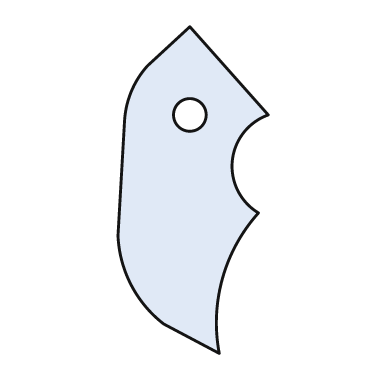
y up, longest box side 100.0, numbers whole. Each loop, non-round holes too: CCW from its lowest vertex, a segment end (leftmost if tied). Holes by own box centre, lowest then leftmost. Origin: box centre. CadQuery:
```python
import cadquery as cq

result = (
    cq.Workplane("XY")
    .moveTo(8.0, -50.0)
    .threePointArc((9.0, -27.0), (20.0, -7.0))
    .threePointArc((12.0, 9.0), (23.0, 23.0))
    .lineTo(-1.0, 50.0)
    .lineTo(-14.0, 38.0)
    .threePointArc((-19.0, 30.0), (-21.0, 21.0))
    .lineTo(-23.0, -14.0)
    .threePointArc((-19.0, -29.0), (-9.0, -41.0))
    .close()
    .moveTo(-1.0, 23.0)
    .circle(5.0)
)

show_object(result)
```